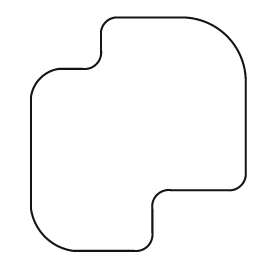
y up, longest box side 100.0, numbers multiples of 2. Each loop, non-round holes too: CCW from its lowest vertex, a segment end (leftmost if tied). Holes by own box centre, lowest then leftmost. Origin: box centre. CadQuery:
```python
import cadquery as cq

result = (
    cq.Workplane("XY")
    .moveTo(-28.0, -50.0)
    .lineTo(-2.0, -50.0)
    .threePointArc((4.0, -48.0), (6.0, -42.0))
    .lineTo(6.0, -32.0)
    .threePointArc((8.0, -26.0), (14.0, -24.0))
    .lineTo(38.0, -24.0)
    .threePointArc((44.0, -22.0), (46.0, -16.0))
    .lineTo(46.0, 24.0)
    .threePointArc((38.0, 42.0), (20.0, 50.0))
    .lineTo(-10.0, 50.0)
    .threePointArc((-14.0, 48.0), (-16.0, 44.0))
    .lineTo(-16.0, 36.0)
    .threePointArc((-18.0, 30.0), (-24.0, 28.0))
    .lineTo(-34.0, 28.0)
    .threePointArc((-42.0, 24.0), (-46.0, 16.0))
    .lineTo(-46.0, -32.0)
    .threePointArc((-40.0, -44.0), (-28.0, -50.0))
    .close()
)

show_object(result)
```